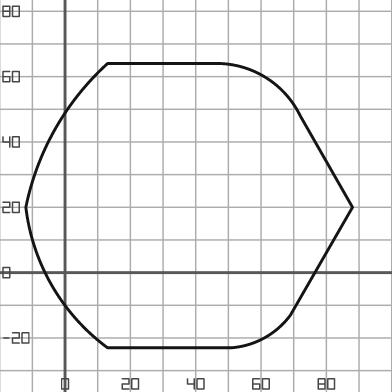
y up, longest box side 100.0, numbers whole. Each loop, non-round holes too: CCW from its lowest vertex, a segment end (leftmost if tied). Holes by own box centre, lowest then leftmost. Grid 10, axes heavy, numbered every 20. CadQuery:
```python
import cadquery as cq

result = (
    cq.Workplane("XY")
    .moveTo(13.0, -23.0)
    .lineTo(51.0, -23.0)
    .threePointArc((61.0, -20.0), (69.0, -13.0))
    .lineTo(88.0, 20.0)
    .lineTo(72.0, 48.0)
    .threePointArc((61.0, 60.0), (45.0, 64.0))
    .lineTo(13.0, 64.0)
    .threePointArc((-3.0, 44.0), (-12.0, 20.0))
    .threePointArc((-4.0, -4.0), (13.0, -23.0))
    .close()
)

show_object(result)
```